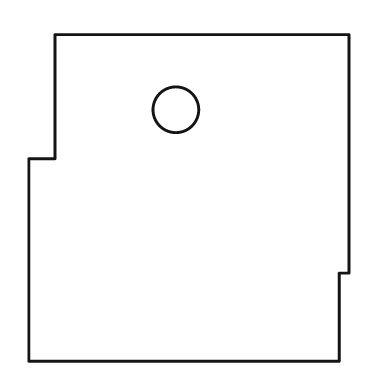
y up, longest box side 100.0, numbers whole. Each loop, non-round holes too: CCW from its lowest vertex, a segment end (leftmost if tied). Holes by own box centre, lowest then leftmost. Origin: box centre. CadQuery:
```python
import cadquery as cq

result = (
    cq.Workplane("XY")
    .moveTo(-49.0, -50.0)
    .lineTo(46.0, -50.0)
    .lineTo(46.0, -23.0)
    .lineTo(49.0, -23.0)
    .lineTo(49.0, 50.0)
    .lineTo(-41.0, 50.0)
    .lineTo(-41.0, 12.0)
    .lineTo(-49.0, 12.0)
    .close()
    .moveTo(-4.0, 27.0)
    .circle(7.0)
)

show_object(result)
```